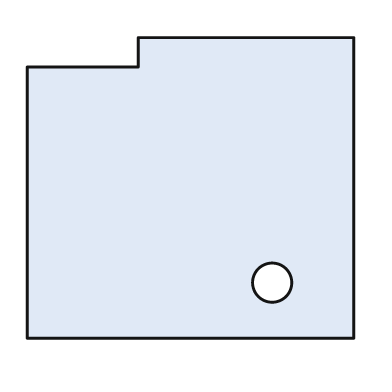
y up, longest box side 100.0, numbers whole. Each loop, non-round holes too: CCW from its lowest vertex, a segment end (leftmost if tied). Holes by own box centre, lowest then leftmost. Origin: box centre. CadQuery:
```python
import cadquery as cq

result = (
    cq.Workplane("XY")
    .moveTo(-50.0, -46.0)
    .lineTo(50.0, -46.0)
    .lineTo(50.0, 46.0)
    .lineTo(-16.0, 46.0)
    .lineTo(-16.0, 37.0)
    .lineTo(-50.0, 37.0)
    .close()
    .moveTo(25.0, -29.0)
    .circle(6.0)
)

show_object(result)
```